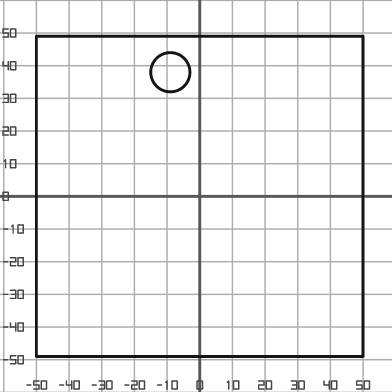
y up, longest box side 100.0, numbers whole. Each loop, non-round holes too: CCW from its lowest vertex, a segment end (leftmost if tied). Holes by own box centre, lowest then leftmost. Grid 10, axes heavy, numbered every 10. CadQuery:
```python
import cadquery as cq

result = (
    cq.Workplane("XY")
    .moveTo(-50.0, -49.0)
    .lineTo(50.0, -49.0)
    .lineTo(50.0, 49.0)
    .lineTo(-50.0, 49.0)
    .close()
    .moveTo(-9.0, 38.0)
    .circle(6.0)
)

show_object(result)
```